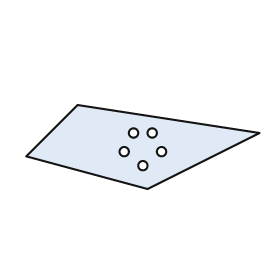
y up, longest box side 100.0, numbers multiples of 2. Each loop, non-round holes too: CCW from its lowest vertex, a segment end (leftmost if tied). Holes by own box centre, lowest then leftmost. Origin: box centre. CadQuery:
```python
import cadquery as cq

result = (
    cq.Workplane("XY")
    .moveTo(2.0, -18.0)
    .lineTo(50.0, 6.0)
    .lineTo(-28.0, 18.0)
    .lineTo(-50.0, -4.0)
    .close()
    .moveTo(0.0, -8.0)
    .circle(2.0)
    .moveTo(-8.0, -2.0)
    .circle(2.0)
    .moveTo(8.0, -2.0)
    .circle(2.0)
    .moveTo(-4.0, 6.0)
    .circle(2.0)
    .moveTo(4.0, 6.0)
    .circle(2.0)
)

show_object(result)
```